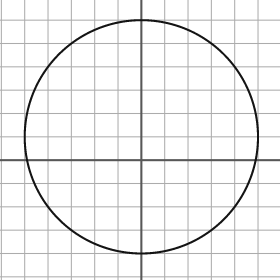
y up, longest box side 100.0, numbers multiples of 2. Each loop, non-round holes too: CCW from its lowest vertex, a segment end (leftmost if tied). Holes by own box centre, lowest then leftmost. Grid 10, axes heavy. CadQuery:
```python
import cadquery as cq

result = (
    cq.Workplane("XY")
    .moveTo(0.0, 10.0)
    .circle(50.0)
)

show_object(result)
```